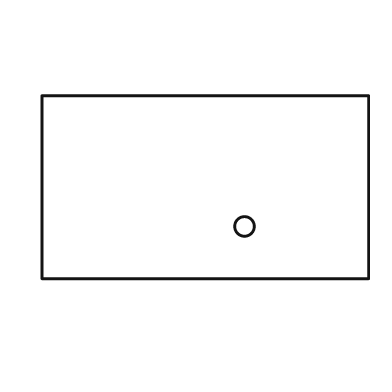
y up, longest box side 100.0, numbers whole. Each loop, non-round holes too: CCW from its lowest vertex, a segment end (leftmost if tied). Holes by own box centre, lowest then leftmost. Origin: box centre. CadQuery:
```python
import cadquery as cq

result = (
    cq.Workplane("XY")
    .moveTo(-50.0, -28.0)
    .lineTo(50.0, -28.0)
    .lineTo(50.0, 28.0)
    .lineTo(-50.0, 28.0)
    .close()
    .moveTo(12.0, -12.0)
    .circle(3.0)
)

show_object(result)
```